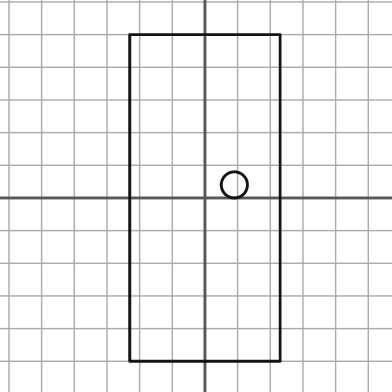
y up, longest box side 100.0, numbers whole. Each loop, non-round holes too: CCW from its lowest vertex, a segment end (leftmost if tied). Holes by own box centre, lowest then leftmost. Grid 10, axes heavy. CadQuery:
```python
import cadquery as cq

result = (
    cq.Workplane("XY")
    .moveTo(-23.0, -50.0)
    .lineTo(23.0, -50.0)
    .lineTo(23.0, 50.0)
    .lineTo(-23.0, 50.0)
    .close()
    .moveTo(9.0, 4.0)
    .circle(4.0)
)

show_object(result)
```